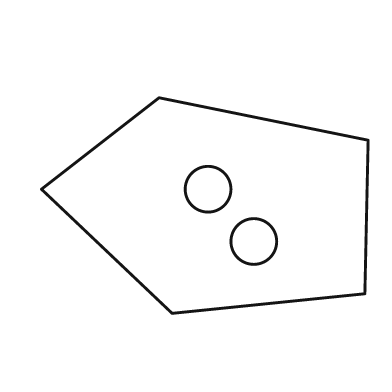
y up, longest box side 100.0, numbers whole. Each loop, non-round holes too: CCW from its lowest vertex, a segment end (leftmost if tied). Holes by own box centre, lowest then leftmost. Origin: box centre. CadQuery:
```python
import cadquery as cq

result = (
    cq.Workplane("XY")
    .moveTo(-10.0, -33.0)
    .lineTo(49.0, -27.0)
    .lineTo(50.0, 20.0)
    .lineTo(-14.0, 33.0)
    .lineTo(-50.0, 5.0)
    .close()
    .moveTo(15.0, -11.0)
    .circle(7.0)
    .moveTo(1.0, 5.0)
    .circle(7.0)
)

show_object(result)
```